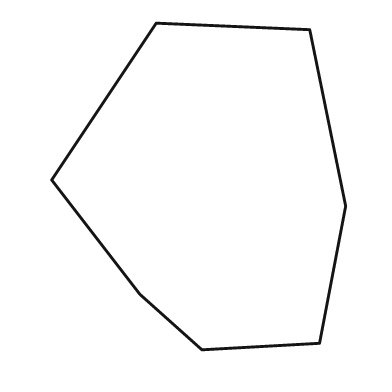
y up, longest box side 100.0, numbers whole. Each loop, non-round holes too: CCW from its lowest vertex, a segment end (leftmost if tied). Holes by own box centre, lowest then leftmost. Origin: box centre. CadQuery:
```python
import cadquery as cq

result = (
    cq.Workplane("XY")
    .moveTo(1.0, -50.0)
    .lineTo(37.0, -48.0)
    .lineTo(45.0, -6.0)
    .lineTo(34.0, 48.0)
    .lineTo(-13.0, 50.0)
    .lineTo(-45.0, 2.0)
    .lineTo(-18.0, -33.0)
    .close()
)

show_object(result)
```